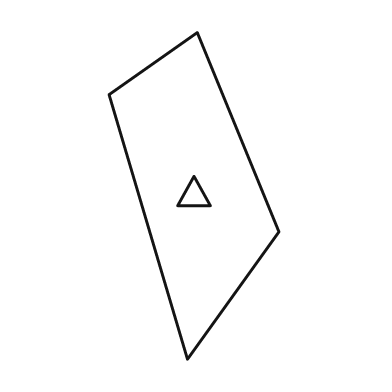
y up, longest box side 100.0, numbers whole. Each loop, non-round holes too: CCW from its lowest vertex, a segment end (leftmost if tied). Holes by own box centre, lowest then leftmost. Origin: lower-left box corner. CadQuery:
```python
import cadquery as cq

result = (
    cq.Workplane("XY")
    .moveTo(24.0, 0.0)
    .lineTo(52.0, 39.0)
    .lineTo(27.0, 100.0)
    .lineTo(0.0, 81.0)
    .close()
    .moveTo(21.0, 47.0)
    .lineTo(31.0, 47.0)
    .lineTo(26.0, 56.0)
    .close()
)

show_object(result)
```